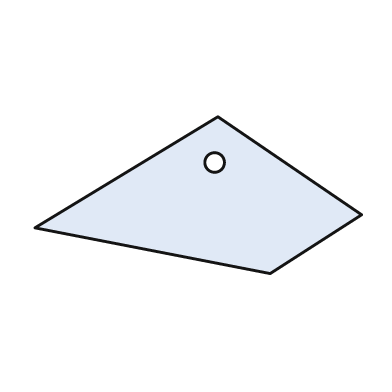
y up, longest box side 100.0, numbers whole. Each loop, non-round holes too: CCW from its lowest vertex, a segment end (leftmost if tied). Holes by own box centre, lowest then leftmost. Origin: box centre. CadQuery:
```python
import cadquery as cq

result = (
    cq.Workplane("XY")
    .moveTo(22.0, -24.0)
    .lineTo(50.0, -6.0)
    .lineTo(6.0, 24.0)
    .lineTo(-50.0, -10.0)
    .close()
    .moveTo(5.0, 10.0)
    .circle(3.0)
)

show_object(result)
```